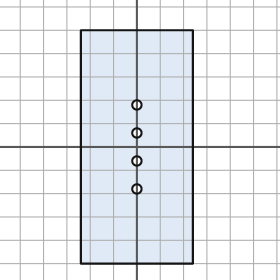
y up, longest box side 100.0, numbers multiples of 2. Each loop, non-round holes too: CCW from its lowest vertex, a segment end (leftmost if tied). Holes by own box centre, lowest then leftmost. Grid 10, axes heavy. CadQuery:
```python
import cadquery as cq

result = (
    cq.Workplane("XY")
    .moveTo(-24.0, -50.0)
    .lineTo(24.0, -50.0)
    .lineTo(24.0, 50.0)
    .lineTo(-24.0, 50.0)
    .close()
    .moveTo(0.0, -18.0)
    .circle(2.0)
    .moveTo(0.0, -6.0)
    .circle(2.0)
    .moveTo(0.0, 6.0)
    .circle(2.0)
    .moveTo(0.0, 18.0)
    .circle(2.0)
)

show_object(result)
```